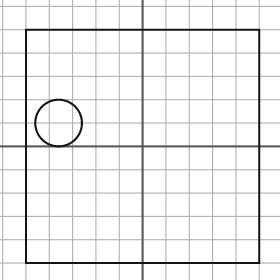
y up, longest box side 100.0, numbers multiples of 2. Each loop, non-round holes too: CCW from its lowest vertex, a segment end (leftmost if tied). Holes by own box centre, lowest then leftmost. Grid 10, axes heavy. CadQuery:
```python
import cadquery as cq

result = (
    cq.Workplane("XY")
    .moveTo(-50.0, -50.0)
    .lineTo(50.0, -50.0)
    .lineTo(50.0, 50.0)
    .lineTo(-50.0, 50.0)
    .close()
    .moveTo(-36.0, 10.0)
    .circle(10.0)
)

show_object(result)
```